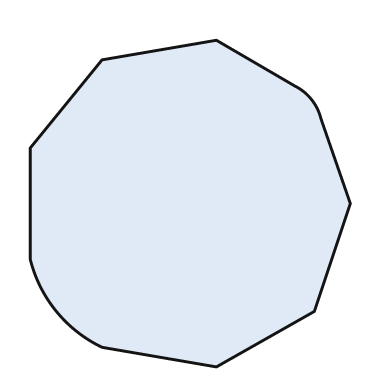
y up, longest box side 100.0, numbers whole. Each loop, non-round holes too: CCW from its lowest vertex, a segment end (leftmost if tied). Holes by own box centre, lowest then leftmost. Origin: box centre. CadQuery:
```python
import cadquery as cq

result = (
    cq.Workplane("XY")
    .moveTo(8.0, -50.0)
    .lineTo(38.0, -33.0)
    .lineTo(49.0, 0.0)
    .lineTo(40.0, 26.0)
    .threePointArc((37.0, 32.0), (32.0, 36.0))
    .lineTo(8.0, 50.0)
    .lineTo(-27.0, 44.0)
    .lineTo(-49.0, 17.0)
    .lineTo(-49.0, -17.0)
    .threePointArc((-41.0, -33.0), (-27.0, -44.0))
    .close()
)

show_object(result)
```